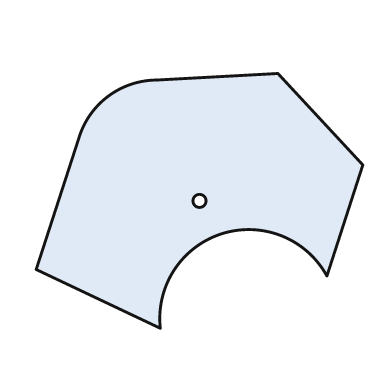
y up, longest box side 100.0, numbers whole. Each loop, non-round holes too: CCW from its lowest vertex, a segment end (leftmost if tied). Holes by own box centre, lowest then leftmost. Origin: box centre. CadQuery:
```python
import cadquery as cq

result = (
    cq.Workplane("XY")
    .moveTo(-12.0, -39.0)
    .threePointArc((7.0, -10.0), (39.0, -23.0))
    .lineTo(50.0, 11.0)
    .lineTo(24.0, 39.0)
    .lineTo(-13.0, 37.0)
    .threePointArc((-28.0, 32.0), (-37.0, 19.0))
    .lineTo(-50.0, -21.0)
    .close()
    .moveTo(0.0, 0.0)
    .circle(2.0)
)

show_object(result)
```